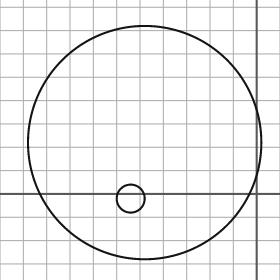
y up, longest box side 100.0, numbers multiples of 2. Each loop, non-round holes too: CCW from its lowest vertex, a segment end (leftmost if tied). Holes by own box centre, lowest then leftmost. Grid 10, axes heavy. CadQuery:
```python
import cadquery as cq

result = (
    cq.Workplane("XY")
    .moveTo(-48.0, 22.0)
    .circle(50.0)
    .moveTo(-54.0, -2.0)
    .circle(6.0)
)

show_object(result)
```